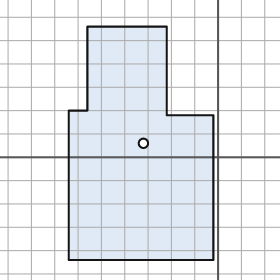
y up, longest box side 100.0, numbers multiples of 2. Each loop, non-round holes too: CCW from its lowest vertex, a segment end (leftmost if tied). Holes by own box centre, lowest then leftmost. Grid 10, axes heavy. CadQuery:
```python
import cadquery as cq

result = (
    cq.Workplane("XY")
    .moveTo(-64.0, -44.0)
    .lineTo(-2.0, -44.0)
    .lineTo(-2.0, 18.0)
    .lineTo(-22.0, 18.0)
    .lineTo(-22.0, 56.0)
    .lineTo(-56.0, 56.0)
    .lineTo(-56.0, 20.0)
    .lineTo(-64.0, 20.0)
    .close()
    .moveTo(-32.0, 6.0)
    .circle(2.0)
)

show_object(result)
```